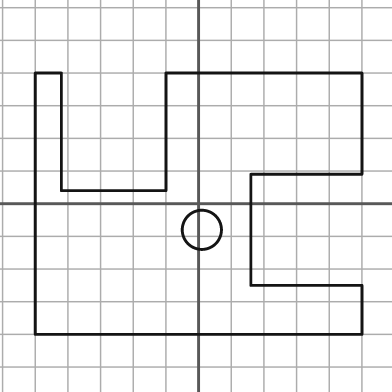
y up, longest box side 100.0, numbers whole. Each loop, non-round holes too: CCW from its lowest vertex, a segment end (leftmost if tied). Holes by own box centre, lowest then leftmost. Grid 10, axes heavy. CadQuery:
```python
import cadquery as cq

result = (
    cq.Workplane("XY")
    .moveTo(-50.0, -40.0)
    .lineTo(50.0, -40.0)
    .lineTo(50.0, -25.0)
    .lineTo(16.0, -25.0)
    .lineTo(16.0, 9.0)
    .lineTo(50.0, 9.0)
    .lineTo(50.0, 40.0)
    .lineTo(-10.0, 40.0)
    .lineTo(-10.0, 4.0)
    .lineTo(-42.0, 4.0)
    .lineTo(-42.0, 40.0)
    .lineTo(-50.0, 40.0)
    .close()
    .moveTo(1.0, -8.0)
    .circle(6.0)
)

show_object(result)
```